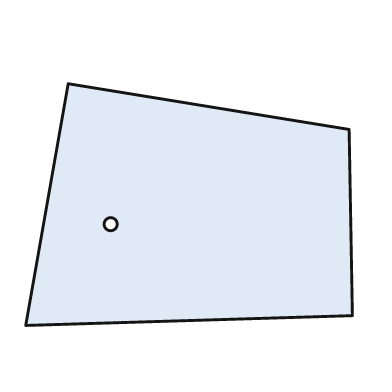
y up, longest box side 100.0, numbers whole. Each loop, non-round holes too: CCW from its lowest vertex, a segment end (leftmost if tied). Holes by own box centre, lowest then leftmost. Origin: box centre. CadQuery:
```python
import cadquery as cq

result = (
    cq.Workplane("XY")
    .moveTo(-50.0, -37.0)
    .lineTo(50.0, -34.0)
    .lineTo(49.0, 23.0)
    .lineTo(-37.0, 37.0)
    .close()
    .moveTo(-24.0, -6.0)
    .circle(2.0)
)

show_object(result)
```